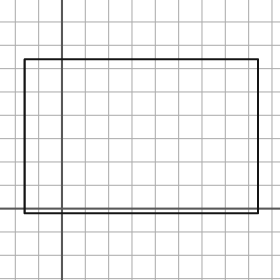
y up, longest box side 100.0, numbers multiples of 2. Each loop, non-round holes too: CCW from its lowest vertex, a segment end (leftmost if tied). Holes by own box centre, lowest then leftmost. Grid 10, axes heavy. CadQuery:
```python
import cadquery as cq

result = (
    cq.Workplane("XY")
    .moveTo(-16.0, -2.0)
    .lineTo(84.0, -2.0)
    .lineTo(84.0, 64.0)
    .lineTo(-16.0, 64.0)
    .close()
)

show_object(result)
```